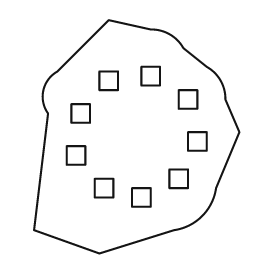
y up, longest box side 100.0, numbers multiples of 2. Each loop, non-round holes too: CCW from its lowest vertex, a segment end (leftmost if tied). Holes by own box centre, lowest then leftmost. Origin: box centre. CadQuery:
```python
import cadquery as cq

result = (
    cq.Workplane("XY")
    .moveTo(-16.0, -50.0)
    .lineTo(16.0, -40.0)
    .threePointArc((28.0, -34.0), (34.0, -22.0))
    .lineTo(44.0, 2.0)
    .lineTo(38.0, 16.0)
    .threePointArc((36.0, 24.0), (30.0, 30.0))
    .lineTo(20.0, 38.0)
    .threePointArc((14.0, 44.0), (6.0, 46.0))
    .lineTo(-12.0, 50.0)
    .lineTo(-34.0, 28.0)
    .threePointArc((-40.0, 20.0), (-38.0, 10.0))
    .lineTo(-44.0, -40.0)
    .close()
    .moveTo(-2.0, -30.0)
    .lineTo(6.0, -30.0)
    .lineTo(6.0, -22.0)
    .lineTo(-2.0, -22.0)
    .close()
    .moveTo(-18.0, -26.0)
    .lineTo(-10.0, -26.0)
    .lineTo(-10.0, -18.0)
    .lineTo(-18.0, -18.0)
    .close()
    .moveTo(14.0, -22.0)
    .lineTo(22.0, -22.0)
    .lineTo(22.0, -14.0)
    .lineTo(14.0, -14.0)
    .close()
    .moveTo(-30.0, -12.0)
    .lineTo(-22.0, -12.0)
    .lineTo(-22.0, -4.0)
    .lineTo(-30.0, -4.0)
    .close()
    .moveTo(22.0, -6.0)
    .lineTo(30.0, -6.0)
    .lineTo(30.0, 2.0)
    .lineTo(22.0, 2.0)
    .close()
    .moveTo(-28.0, 6.0)
    .lineTo(-20.0, 6.0)
    .lineTo(-20.0, 14.0)
    .lineTo(-28.0, 14.0)
    .close()
    .moveTo(18.0, 12.0)
    .lineTo(26.0, 12.0)
    .lineTo(26.0, 20.0)
    .lineTo(18.0, 20.0)
    .close()
    .moveTo(-16.0, 20.0)
    .lineTo(-8.0, 20.0)
    .lineTo(-8.0, 28.0)
    .lineTo(-16.0, 28.0)
    .close()
    .moveTo(2.0, 22.0)
    .lineTo(10.0, 22.0)
    .lineTo(10.0, 30.0)
    .lineTo(2.0, 30.0)
    .close()
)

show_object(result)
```